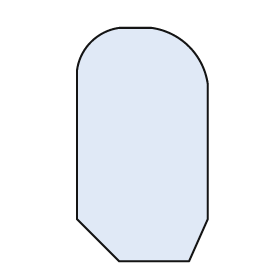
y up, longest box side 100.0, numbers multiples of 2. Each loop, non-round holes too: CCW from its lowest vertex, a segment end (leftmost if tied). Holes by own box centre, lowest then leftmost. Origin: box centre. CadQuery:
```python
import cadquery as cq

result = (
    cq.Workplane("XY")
    .moveTo(-10.0, -50.0)
    .lineTo(20.0, -50.0)
    .lineTo(28.0, -32.0)
    .lineTo(28.0, 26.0)
    .threePointArc((20.0, 42.0), (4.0, 50.0))
    .lineTo(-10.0, 50.0)
    .threePointArc((-22.0, 44.0), (-28.0, 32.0))
    .lineTo(-28.0, -32.0)
    .close()
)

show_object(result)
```